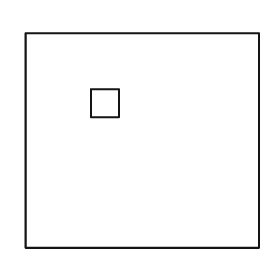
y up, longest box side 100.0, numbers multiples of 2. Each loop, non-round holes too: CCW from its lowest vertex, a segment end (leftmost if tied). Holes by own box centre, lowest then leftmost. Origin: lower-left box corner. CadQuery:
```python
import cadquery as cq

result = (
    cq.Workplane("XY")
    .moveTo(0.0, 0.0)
    .lineTo(100.0, 0.0)
    .lineTo(100.0, 92.0)
    .lineTo(0.0, 92.0)
    .close()
    .moveTo(28.0, 56.0)
    .lineTo(40.0, 56.0)
    .lineTo(40.0, 68.0)
    .lineTo(28.0, 68.0)
    .close()
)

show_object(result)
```